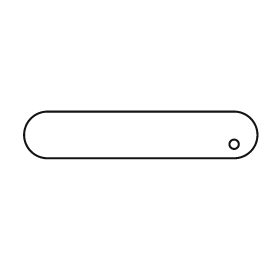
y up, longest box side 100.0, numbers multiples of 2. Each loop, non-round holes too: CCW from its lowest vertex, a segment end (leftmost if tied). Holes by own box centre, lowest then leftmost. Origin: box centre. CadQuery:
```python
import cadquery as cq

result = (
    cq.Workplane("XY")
    .moveTo(-40.0, -10.0)
    .lineTo(40.0, -10.0)
    .threePointArc((50.0, 0.0), (40.0, 10.0))
    .lineTo(-40.0, 10.0)
    .threePointArc((-50.0, 0.0), (-40.0, -10.0))
    .close()
    .moveTo(40.0, -4.0)
    .circle(2.0)
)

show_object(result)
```